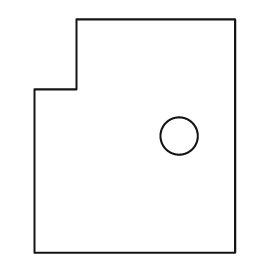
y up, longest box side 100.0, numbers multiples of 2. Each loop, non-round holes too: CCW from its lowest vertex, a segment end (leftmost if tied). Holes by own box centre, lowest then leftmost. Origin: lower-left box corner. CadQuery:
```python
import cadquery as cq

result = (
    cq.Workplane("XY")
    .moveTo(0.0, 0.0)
    .lineTo(86.0, 0.0)
    .lineTo(86.0, 100.0)
    .lineTo(18.0, 100.0)
    .lineTo(18.0, 70.0)
    .lineTo(0.0, 70.0)
    .close()
    .moveTo(62.0, 50.0)
    .circle(8.0)
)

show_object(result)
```